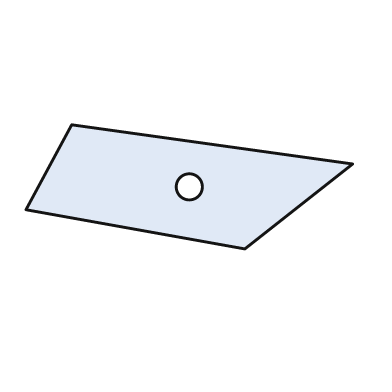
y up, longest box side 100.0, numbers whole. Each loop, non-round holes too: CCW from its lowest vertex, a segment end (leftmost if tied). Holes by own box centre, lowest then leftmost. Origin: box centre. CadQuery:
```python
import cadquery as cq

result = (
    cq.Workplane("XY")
    .moveTo(17.0, -19.0)
    .lineTo(50.0, 7.0)
    .lineTo(-36.0, 19.0)
    .lineTo(-50.0, -7.0)
    .close()
    .moveTo(0.0, 0.0)
    .circle(4.0)
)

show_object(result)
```